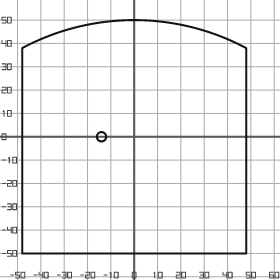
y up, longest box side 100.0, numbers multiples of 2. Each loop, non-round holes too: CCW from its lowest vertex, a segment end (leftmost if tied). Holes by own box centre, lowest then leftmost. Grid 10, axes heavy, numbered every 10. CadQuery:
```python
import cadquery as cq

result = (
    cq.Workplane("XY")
    .moveTo(-48.0, -50.0)
    .lineTo(48.0, -50.0)
    .lineTo(48.0, 38.0)
    .threePointArc((0.0, 50.0), (-48.0, 38.0))
    .close()
    .moveTo(-14.0, 0.0)
    .circle(2.0)
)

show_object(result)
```